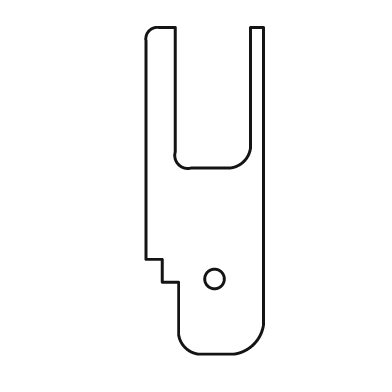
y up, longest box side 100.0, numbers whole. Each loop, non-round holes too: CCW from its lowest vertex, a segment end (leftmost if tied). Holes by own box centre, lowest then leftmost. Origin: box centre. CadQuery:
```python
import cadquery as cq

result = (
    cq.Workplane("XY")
    .moveTo(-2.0, -50.0)
    .lineTo(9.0, -50.0)
    .threePointArc((15.0, -47.0), (18.0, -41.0))
    .lineTo(18.0, 50.0)
    .lineTo(14.0, 50.0)
    .lineTo(14.0, 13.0)
    .threePointArc((12.0, 9.0), (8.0, 7.0))
    .lineTo(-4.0, 7.0)
    .threePointArc((-8.0, 8.0), (-9.0, 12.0))
    .lineTo(-9.0, 50.0)
    .lineTo(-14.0, 50.0)
    .threePointArc((-17.0, 49.0), (-18.0, 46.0))
    .lineTo(-18.0, -21.0)
    .lineTo(-13.0, -21.0)
    .lineTo(-13.0, -28.0)
    .lineTo(-8.0, -28.0)
    .lineTo(-8.0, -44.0)
    .threePointArc((-6.0, -48.0), (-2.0, -50.0))
    .close()
    .moveTo(3.0, -27.0)
    .circle(3.0)
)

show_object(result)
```